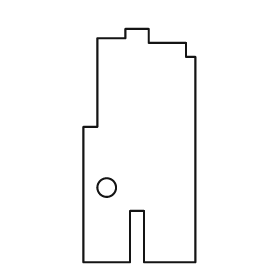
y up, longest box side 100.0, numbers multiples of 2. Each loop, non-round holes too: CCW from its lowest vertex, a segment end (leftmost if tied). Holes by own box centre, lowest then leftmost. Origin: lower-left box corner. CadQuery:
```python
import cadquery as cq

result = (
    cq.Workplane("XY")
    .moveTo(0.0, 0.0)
    .lineTo(20.0, 0.0)
    .lineTo(20.0, 22.0)
    .lineTo(26.0, 22.0)
    .lineTo(26.0, 0.0)
    .lineTo(48.0, 0.0)
    .lineTo(48.0, 88.0)
    .lineTo(44.0, 88.0)
    .lineTo(44.0, 94.0)
    .lineTo(28.0, 94.0)
    .lineTo(28.0, 100.0)
    .lineTo(18.0, 100.0)
    .lineTo(18.0, 96.0)
    .lineTo(6.0, 96.0)
    .lineTo(6.0, 58.0)
    .lineTo(0.0, 58.0)
    .close()
    .moveTo(10.0, 32.0)
    .circle(4.0)
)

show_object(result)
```